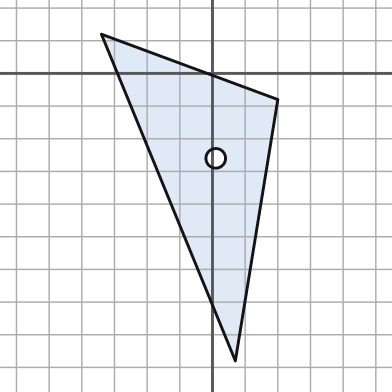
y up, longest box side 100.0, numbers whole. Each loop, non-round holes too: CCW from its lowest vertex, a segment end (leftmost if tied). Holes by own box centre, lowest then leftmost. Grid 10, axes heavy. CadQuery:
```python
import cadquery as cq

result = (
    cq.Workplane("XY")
    .moveTo(7.0, -88.0)
    .lineTo(20.0, -8.0)
    .lineTo(-34.0, 12.0)
    .close()
    .moveTo(1.0, -26.0)
    .circle(3.0)
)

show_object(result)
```